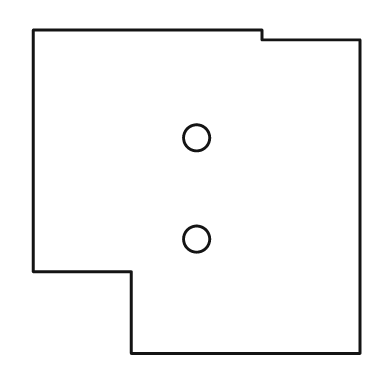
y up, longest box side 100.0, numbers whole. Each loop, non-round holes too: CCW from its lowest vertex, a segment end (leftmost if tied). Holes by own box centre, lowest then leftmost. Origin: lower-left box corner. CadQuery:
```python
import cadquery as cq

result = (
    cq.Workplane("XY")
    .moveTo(30.0, 0.0)
    .lineTo(100.0, 0.0)
    .lineTo(100.0, 96.0)
    .lineTo(70.0, 96.0)
    .lineTo(70.0, 99.0)
    .lineTo(0.0, 99.0)
    .lineTo(0.0, 25.0)
    .lineTo(30.0, 25.0)
    .close()
    .moveTo(50.0, 35.0)
    .circle(4.0)
    .moveTo(50.0, 66.0)
    .circle(4.0)
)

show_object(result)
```